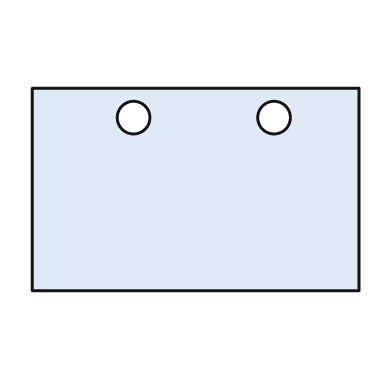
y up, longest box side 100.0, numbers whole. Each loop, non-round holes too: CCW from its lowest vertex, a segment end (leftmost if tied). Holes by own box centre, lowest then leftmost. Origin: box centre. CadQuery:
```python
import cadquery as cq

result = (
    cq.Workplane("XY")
    .moveTo(-50.0, -31.0)
    .lineTo(50.0, -31.0)
    .lineTo(50.0, 31.0)
    .lineTo(-50.0, 31.0)
    .close()
    .moveTo(-19.0, 22.0)
    .circle(5.0)
    .moveTo(24.0, 22.0)
    .circle(5.0)
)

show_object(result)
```